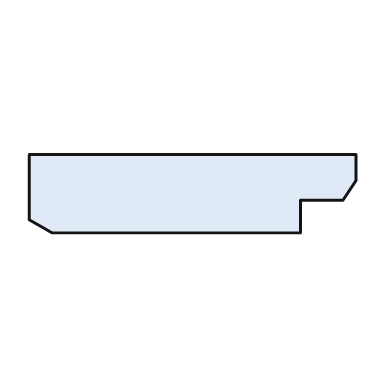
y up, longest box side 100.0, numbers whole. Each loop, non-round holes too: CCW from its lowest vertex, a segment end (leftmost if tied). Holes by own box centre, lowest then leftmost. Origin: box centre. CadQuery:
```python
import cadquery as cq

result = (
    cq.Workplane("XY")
    .moveTo(-43.0, -12.0)
    .lineTo(33.0, -12.0)
    .lineTo(33.0, -2.0)
    .lineTo(46.0, -2.0)
    .lineTo(50.0, 4.0)
    .lineTo(50.0, 12.0)
    .lineTo(-50.0, 12.0)
    .lineTo(-50.0, -8.0)
    .close()
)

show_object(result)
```